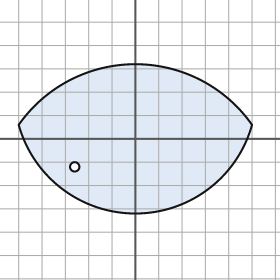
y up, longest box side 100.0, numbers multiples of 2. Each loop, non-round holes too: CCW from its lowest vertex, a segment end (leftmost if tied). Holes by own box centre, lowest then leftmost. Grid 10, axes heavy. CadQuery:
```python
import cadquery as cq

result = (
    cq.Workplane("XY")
    .moveTo(-50.0, 6.0)
    .threePointArc((0.0, -32.0), (50.0, 6.0))
    .threePointArc((0.0, 32.0), (-50.0, 6.0))
    .close()
    .moveTo(-26.0, -12.0)
    .circle(2.0)
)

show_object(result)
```